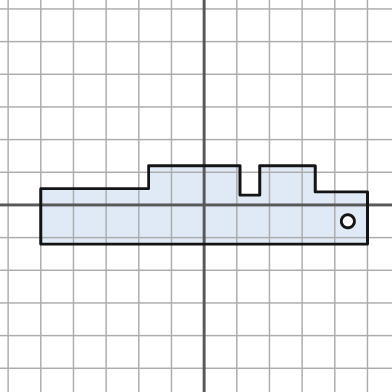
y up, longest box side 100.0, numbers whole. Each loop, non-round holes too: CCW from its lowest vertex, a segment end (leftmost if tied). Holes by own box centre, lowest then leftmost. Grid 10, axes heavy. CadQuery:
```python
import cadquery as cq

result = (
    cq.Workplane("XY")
    .moveTo(-50.0, -12.0)
    .lineTo(50.0, -12.0)
    .lineTo(50.0, 4.0)
    .lineTo(34.0, 4.0)
    .lineTo(34.0, 12.0)
    .lineTo(17.0, 12.0)
    .lineTo(17.0, 3.0)
    .lineTo(11.0, 3.0)
    .lineTo(11.0, 12.0)
    .lineTo(-17.0, 12.0)
    .lineTo(-17.0, 5.0)
    .lineTo(-50.0, 5.0)
    .close()
    .moveTo(44.0, -5.0)
    .circle(2.0)
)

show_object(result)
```